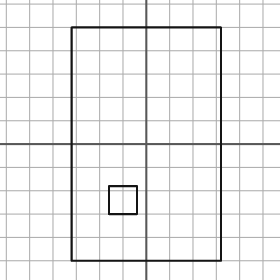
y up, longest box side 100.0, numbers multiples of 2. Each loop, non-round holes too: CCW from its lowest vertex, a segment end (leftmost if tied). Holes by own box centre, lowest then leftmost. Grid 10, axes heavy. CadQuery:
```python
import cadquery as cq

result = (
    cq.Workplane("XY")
    .moveTo(-32.0, -50.0)
    .lineTo(32.0, -50.0)
    .lineTo(32.0, 50.0)
    .lineTo(-32.0, 50.0)
    .close()
    .moveTo(-16.0, -30.0)
    .lineTo(-4.0, -30.0)
    .lineTo(-4.0, -18.0)
    .lineTo(-16.0, -18.0)
    .close()
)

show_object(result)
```